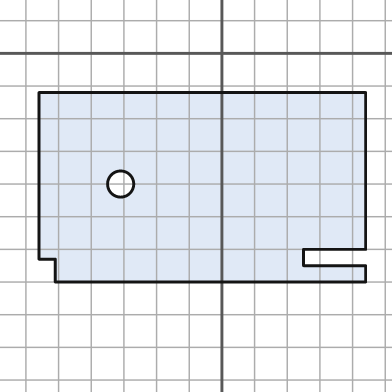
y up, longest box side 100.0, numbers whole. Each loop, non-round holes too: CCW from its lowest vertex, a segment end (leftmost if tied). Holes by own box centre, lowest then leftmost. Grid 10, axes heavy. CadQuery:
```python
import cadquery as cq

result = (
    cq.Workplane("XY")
    .moveTo(-51.0, -70.0)
    .lineTo(44.0, -70.0)
    .lineTo(44.0, -65.0)
    .lineTo(25.0, -65.0)
    .lineTo(25.0, -60.0)
    .lineTo(44.0, -60.0)
    .lineTo(44.0, -12.0)
    .lineTo(-56.0, -12.0)
    .lineTo(-56.0, -63.0)
    .lineTo(-51.0, -63.0)
    .close()
    .moveTo(-31.0, -40.0)
    .circle(4.0)
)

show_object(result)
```